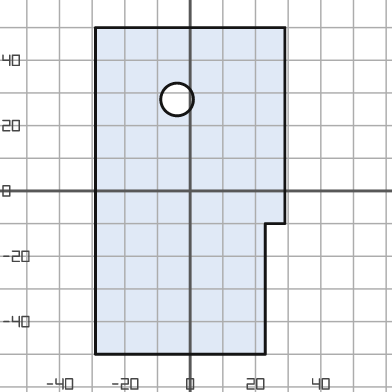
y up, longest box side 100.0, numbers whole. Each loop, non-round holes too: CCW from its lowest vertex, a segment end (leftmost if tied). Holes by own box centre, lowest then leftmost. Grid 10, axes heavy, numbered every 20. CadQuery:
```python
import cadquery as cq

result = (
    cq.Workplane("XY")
    .moveTo(-29.0, -50.0)
    .lineTo(23.0, -50.0)
    .lineTo(23.0, -10.0)
    .lineTo(29.0, -10.0)
    .lineTo(29.0, 50.0)
    .lineTo(-29.0, 50.0)
    .close()
    .moveTo(-4.0, 28.0)
    .circle(5.0)
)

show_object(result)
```